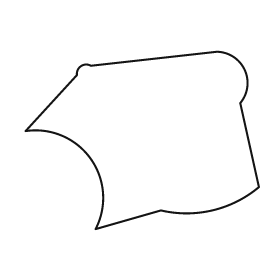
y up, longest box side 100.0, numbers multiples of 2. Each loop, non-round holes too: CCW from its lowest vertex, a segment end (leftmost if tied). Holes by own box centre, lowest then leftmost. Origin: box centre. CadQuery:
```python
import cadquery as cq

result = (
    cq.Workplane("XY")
    .moveTo(-20.0, -38.0)
    .lineTo(8.0, -30.0)
    .threePointArc((30.0, -30.0), (50.0, -20.0))
    .lineTo(42.0, 16.0)
    .threePointArc((44.0, 30.0), (32.0, 38.0))
    .lineTo(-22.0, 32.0)
    .threePointArc((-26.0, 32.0), (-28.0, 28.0))
    .lineTo(-50.0, 4.0)
    .threePointArc((-22.0, -8.0), (-20.0, -38.0))
    .close()
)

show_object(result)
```